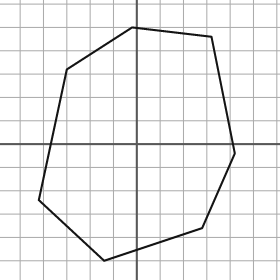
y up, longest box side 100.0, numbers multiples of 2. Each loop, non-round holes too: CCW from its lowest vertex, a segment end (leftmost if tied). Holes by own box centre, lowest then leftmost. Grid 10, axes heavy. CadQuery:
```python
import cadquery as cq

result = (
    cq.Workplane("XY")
    .moveTo(-14.0, -50.0)
    .lineTo(28.0, -36.0)
    .lineTo(42.0, -4.0)
    .lineTo(32.0, 46.0)
    .lineTo(-2.0, 50.0)
    .lineTo(-30.0, 32.0)
    .lineTo(-42.0, -24.0)
    .close()
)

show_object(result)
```